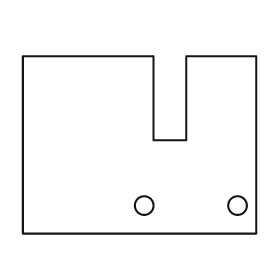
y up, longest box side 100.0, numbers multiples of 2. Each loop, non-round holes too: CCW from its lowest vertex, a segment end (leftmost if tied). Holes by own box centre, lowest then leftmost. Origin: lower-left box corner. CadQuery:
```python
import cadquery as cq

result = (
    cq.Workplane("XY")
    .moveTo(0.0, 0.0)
    .lineTo(100.0, 0.0)
    .lineTo(100.0, 76.0)
    .lineTo(70.0, 76.0)
    .lineTo(70.0, 40.0)
    .lineTo(56.0, 40.0)
    .lineTo(56.0, 76.0)
    .lineTo(0.0, 76.0)
    .close()
    .moveTo(52.0, 12.0)
    .circle(4.0)
    .moveTo(92.0, 12.0)
    .circle(4.0)
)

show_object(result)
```